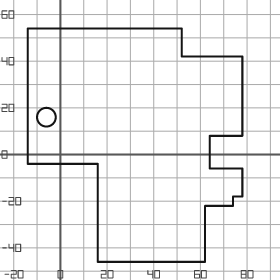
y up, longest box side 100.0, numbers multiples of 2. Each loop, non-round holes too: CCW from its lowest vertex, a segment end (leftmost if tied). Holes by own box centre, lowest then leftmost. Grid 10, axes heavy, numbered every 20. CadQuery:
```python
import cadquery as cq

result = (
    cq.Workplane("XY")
    .moveTo(16.0, -46.0)
    .lineTo(62.0, -46.0)
    .lineTo(62.0, -22.0)
    .lineTo(74.0, -22.0)
    .lineTo(74.0, -18.0)
    .lineTo(78.0, -18.0)
    .lineTo(78.0, -6.0)
    .lineTo(64.0, -6.0)
    .lineTo(64.0, 8.0)
    .lineTo(78.0, 8.0)
    .lineTo(78.0, 42.0)
    .lineTo(52.0, 42.0)
    .lineTo(52.0, 54.0)
    .lineTo(-14.0, 54.0)
    .lineTo(-14.0, -4.0)
    .lineTo(16.0, -4.0)
    .close()
    .moveTo(-6.0, 16.0)
    .circle(4.0)
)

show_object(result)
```